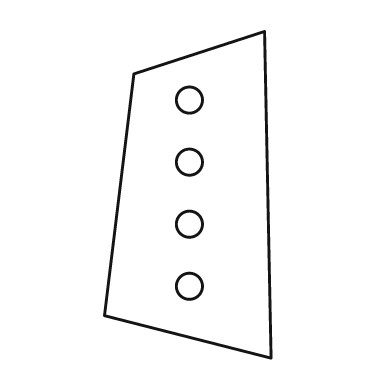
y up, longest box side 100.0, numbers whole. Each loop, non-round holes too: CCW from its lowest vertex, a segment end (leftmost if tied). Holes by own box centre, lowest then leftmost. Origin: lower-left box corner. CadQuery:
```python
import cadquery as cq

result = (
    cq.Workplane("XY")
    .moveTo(51.0, 0.0)
    .lineTo(49.0, 100.0)
    .lineTo(9.0, 87.0)
    .lineTo(0.0, 13.0)
    .close()
    .moveTo(26.0, 22.0)
    .circle(4.0)
    .moveTo(26.0, 41.0)
    .circle(4.0)
    .moveTo(26.0, 60.0)
    .circle(4.0)
    .moveTo(26.0, 79.0)
    .circle(4.0)
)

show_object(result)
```